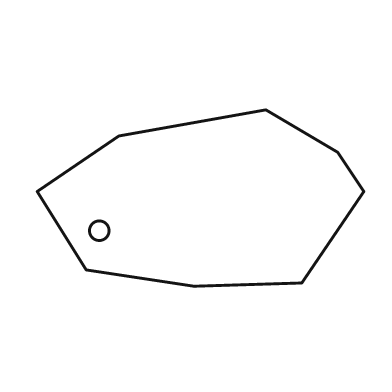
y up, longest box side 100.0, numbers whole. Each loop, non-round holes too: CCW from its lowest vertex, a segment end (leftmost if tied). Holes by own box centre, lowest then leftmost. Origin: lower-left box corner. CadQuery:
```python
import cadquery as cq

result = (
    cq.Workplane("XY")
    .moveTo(48.0, 0.0)
    .lineTo(81.0, 1.0)
    .lineTo(100.0, 29.0)
    .lineTo(92.0, 41.0)
    .lineTo(70.0, 54.0)
    .lineTo(25.0, 46.0)
    .lineTo(0.0, 29.0)
    .lineTo(15.0, 5.0)
    .close()
    .moveTo(19.0, 17.0)
    .circle(3.0)
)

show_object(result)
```